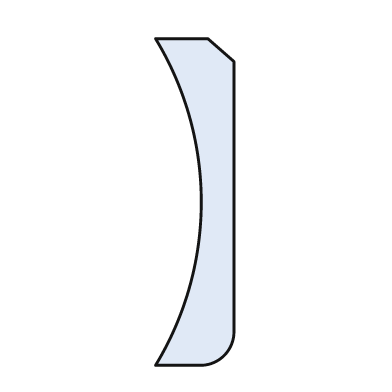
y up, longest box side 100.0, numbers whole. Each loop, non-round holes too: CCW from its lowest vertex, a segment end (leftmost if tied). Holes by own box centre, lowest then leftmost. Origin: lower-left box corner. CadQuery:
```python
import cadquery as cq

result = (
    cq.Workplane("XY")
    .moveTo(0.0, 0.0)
    .lineTo(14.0, 0.0)
    .threePointArc((21.0, 3.0), (24.0, 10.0))
    .lineTo(24.0, 93.0)
    .lineTo(16.0, 100.0)
    .lineTo(0.0, 100.0)
    .threePointArc((14.0, 50.0), (0.0, 0.0))
    .close()
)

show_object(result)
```